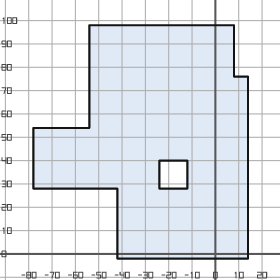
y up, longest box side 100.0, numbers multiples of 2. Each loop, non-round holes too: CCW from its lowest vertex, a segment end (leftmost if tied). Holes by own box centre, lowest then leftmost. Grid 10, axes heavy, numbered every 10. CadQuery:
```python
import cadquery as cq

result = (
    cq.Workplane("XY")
    .moveTo(-42.0, -2.0)
    .lineTo(14.0, -2.0)
    .lineTo(14.0, 76.0)
    .lineTo(8.0, 76.0)
    .lineTo(8.0, 98.0)
    .lineTo(-54.0, 98.0)
    .lineTo(-54.0, 54.0)
    .lineTo(-78.0, 54.0)
    .lineTo(-78.0, 28.0)
    .lineTo(-42.0, 28.0)
    .close()
    .moveTo(-24.0, 28.0)
    .lineTo(-12.0, 28.0)
    .lineTo(-12.0, 40.0)
    .lineTo(-24.0, 40.0)
    .close()
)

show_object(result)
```